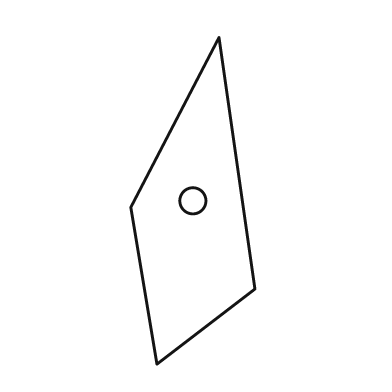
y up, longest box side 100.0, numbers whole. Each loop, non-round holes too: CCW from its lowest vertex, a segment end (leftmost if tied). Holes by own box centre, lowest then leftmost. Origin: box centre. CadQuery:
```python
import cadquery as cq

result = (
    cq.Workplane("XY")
    .moveTo(-11.0, -50.0)
    .lineTo(19.0, -27.0)
    .lineTo(8.0, 50.0)
    .lineTo(-19.0, -2.0)
    .close()
    .moveTo(0.0, 0.0)
    .circle(4.0)
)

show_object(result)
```